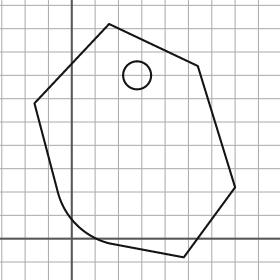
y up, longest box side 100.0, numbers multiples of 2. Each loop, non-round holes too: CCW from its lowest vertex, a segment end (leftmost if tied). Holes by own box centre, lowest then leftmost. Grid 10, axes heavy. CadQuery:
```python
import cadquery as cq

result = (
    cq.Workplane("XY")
    .moveTo(48.0, -8.0)
    .lineTo(70.0, 22.0)
    .lineTo(54.0, 74.0)
    .lineTo(16.0, 92.0)
    .lineTo(-16.0, 58.0)
    .lineTo(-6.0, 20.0)
    .threePointArc((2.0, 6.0), (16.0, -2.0))
    .close()
    .moveTo(28.0, 70.0)
    .circle(6.0)
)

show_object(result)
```